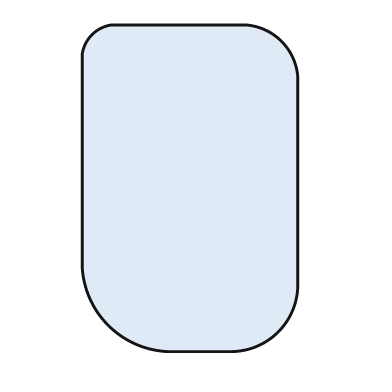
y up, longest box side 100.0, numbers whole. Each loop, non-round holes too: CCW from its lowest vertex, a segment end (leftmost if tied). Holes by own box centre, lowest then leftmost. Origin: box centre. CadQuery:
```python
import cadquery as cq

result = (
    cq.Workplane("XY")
    .moveTo(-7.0, -50.0)
    .lineTo(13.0, -50.0)
    .threePointArc((27.0, -44.0), (33.0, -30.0))
    .lineTo(33.0, 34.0)
    .threePointArc((28.0, 45.0), (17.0, 50.0))
    .lineTo(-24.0, 50.0)
    .threePointArc((-30.0, 47.0), (-33.0, 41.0))
    .lineTo(-33.0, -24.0)
    .threePointArc((-25.0, -42.0), (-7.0, -50.0))
    .close()
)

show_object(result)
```